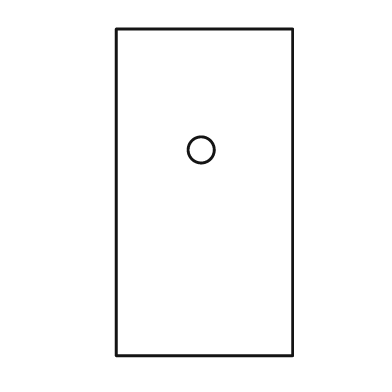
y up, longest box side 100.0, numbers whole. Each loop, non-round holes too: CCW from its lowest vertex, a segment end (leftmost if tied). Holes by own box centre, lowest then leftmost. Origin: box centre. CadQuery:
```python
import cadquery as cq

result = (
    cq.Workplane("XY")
    .moveTo(-27.0, -50.0)
    .lineTo(27.0, -50.0)
    .lineTo(27.0, 50.0)
    .lineTo(-27.0, 50.0)
    .close()
    .moveTo(-1.0, 13.0)
    .circle(4.0)
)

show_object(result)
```